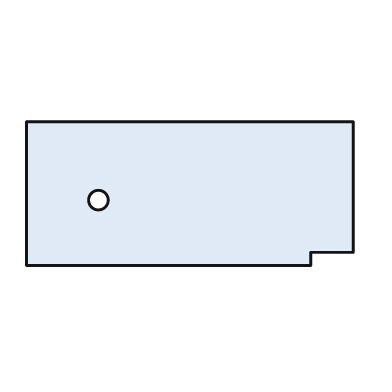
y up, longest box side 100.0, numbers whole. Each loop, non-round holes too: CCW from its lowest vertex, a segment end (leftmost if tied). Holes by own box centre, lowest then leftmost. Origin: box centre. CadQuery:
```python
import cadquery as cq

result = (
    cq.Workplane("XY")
    .moveTo(-50.0, -22.0)
    .lineTo(37.0, -22.0)
    .lineTo(37.0, -18.0)
    .lineTo(50.0, -18.0)
    .lineTo(50.0, 22.0)
    .lineTo(-50.0, 22.0)
    .close()
    .moveTo(-28.0, -2.0)
    .circle(3.0)
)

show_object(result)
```